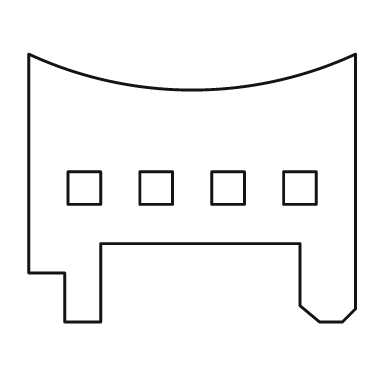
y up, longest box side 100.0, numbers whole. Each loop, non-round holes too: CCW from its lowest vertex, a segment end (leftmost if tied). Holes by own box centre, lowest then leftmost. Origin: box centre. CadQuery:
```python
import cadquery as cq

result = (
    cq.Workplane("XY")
    .moveTo(-39.0, -41.0)
    .lineTo(-28.0, -41.0)
    .lineTo(-28.0, -17.0)
    .lineTo(33.0, -17.0)
    .lineTo(33.0, -36.0)
    .lineTo(39.0, -41.0)
    .lineTo(46.0, -41.0)
    .lineTo(50.0, -37.0)
    .lineTo(50.0, 41.0)
    .threePointArc((0.0, 30.0), (-50.0, 41.0))
    .lineTo(-50.0, -26.0)
    .lineTo(-39.0, -26.0)
    .close()
    .moveTo(-38.0, -5.0)
    .lineTo(-28.0, -5.0)
    .lineTo(-28.0, 5.0)
    .lineTo(-38.0, 5.0)
    .close()
    .moveTo(-16.0, -5.0)
    .lineTo(-6.0, -5.0)
    .lineTo(-6.0, 5.0)
    .lineTo(-16.0, 5.0)
    .close()
    .moveTo(6.0, -5.0)
    .lineTo(16.0, -5.0)
    .lineTo(16.0, 5.0)
    .lineTo(6.0, 5.0)
    .close()
    .moveTo(28.0, -5.0)
    .lineTo(38.0, -5.0)
    .lineTo(38.0, 5.0)
    .lineTo(28.0, 5.0)
    .close()
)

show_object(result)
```